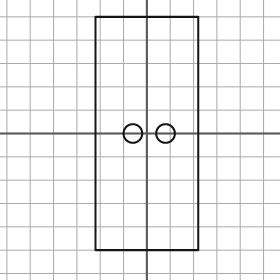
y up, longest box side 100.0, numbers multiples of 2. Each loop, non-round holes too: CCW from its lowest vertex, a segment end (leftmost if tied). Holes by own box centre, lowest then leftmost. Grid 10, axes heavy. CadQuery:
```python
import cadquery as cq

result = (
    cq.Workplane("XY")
    .moveTo(-22.0, -50.0)
    .lineTo(22.0, -50.0)
    .lineTo(22.0, 50.0)
    .lineTo(-22.0, 50.0)
    .close()
    .moveTo(-6.0, 0.0)
    .circle(4.0)
    .moveTo(8.0, 0.0)
    .circle(4.0)
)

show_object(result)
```